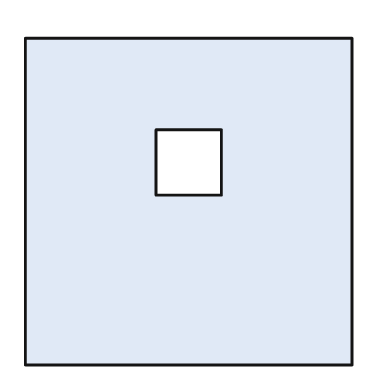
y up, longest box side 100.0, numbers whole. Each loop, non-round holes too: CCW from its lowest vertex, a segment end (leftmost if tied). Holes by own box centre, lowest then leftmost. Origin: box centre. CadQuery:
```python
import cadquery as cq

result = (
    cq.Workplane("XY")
    .moveTo(-50.0, -50.0)
    .lineTo(50.0, -50.0)
    .lineTo(50.0, 50.0)
    .lineTo(-50.0, 50.0)
    .close()
    .moveTo(-10.0, 2.0)
    .lineTo(10.0, 2.0)
    .lineTo(10.0, 22.0)
    .lineTo(-10.0, 22.0)
    .close()
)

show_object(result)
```